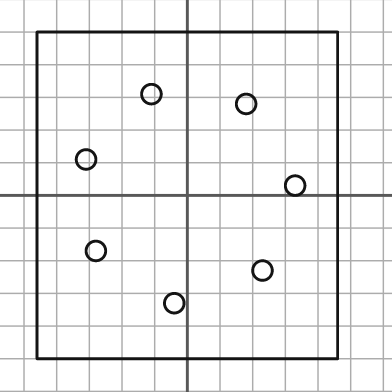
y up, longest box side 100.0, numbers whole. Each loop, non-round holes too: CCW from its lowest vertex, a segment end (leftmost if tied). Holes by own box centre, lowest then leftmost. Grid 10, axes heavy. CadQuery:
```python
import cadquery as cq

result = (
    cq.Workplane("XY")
    .moveTo(-46.0, -50.0)
    .lineTo(46.0, -50.0)
    .lineTo(46.0, 50.0)
    .lineTo(-46.0, 50.0)
    .close()
    .moveTo(-4.0, -33.0)
    .circle(3.0)
    .moveTo(23.0, -23.0)
    .circle(3.0)
    .moveTo(-28.0, -17.0)
    .circle(3.0)
    .moveTo(33.0, 3.0)
    .circle(3.0)
    .moveTo(-31.0, 11.0)
    .circle(3.0)
    .moveTo(18.0, 28.0)
    .circle(3.0)
    .moveTo(-11.0, 31.0)
    .circle(3.0)
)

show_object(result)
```